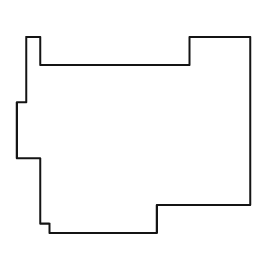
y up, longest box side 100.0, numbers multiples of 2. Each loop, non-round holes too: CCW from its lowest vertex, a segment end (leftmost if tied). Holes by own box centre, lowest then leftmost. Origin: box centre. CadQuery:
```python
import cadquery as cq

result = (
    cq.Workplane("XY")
    .moveTo(-36.0, -42.0)
    .lineTo(10.0, -42.0)
    .lineTo(10.0, -30.0)
    .lineTo(50.0, -30.0)
    .lineTo(50.0, 42.0)
    .lineTo(24.0, 42.0)
    .lineTo(24.0, 30.0)
    .lineTo(-40.0, 30.0)
    .lineTo(-40.0, 42.0)
    .lineTo(-46.0, 42.0)
    .lineTo(-46.0, 14.0)
    .lineTo(-50.0, 14.0)
    .lineTo(-50.0, -10.0)
    .lineTo(-40.0, -10.0)
    .lineTo(-40.0, -38.0)
    .lineTo(-36.0, -38.0)
    .close()
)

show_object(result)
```